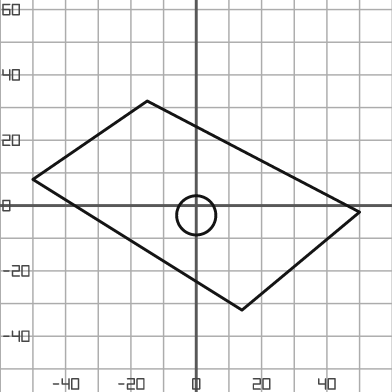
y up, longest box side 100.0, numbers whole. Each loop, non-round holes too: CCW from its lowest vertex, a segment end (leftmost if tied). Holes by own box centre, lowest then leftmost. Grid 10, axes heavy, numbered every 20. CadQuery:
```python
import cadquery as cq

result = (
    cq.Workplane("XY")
    .moveTo(14.0, -32.0)
    .lineTo(50.0, -2.0)
    .lineTo(-15.0, 32.0)
    .lineTo(-50.0, 8.0)
    .close()
    .moveTo(0.0, -3.0)
    .circle(6.0)
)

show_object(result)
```